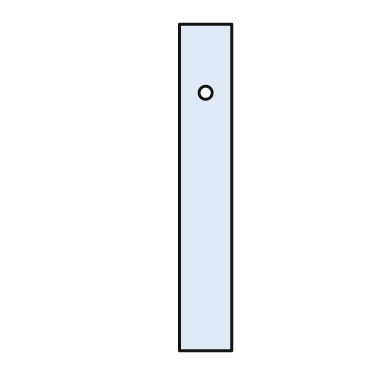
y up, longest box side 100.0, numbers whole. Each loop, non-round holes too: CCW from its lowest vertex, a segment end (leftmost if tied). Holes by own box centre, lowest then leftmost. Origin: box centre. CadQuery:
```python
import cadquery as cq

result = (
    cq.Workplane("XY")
    .moveTo(-8.0, -50.0)
    .lineTo(8.0, -50.0)
    .lineTo(8.0, 50.0)
    .lineTo(-8.0, 50.0)
    .close()
    .moveTo(0.0, 29.0)
    .circle(2.0)
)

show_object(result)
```